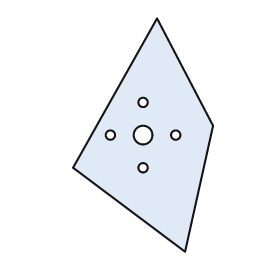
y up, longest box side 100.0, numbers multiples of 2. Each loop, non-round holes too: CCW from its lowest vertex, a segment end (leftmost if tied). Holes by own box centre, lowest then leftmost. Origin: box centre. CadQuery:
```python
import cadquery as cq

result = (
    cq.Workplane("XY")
    .moveTo(18.0, -50.0)
    .lineTo(30.0, 4.0)
    .lineTo(6.0, 50.0)
    .lineTo(-30.0, -14.0)
    .close()
    .moveTo(0.0, -14.0)
    .circle(2.0)
    .moveTo(-14.0, 0.0)
    .circle(2.0)
    .moveTo(0.0, 0.0)
    .circle(4.0)
    .moveTo(14.0, 0.0)
    .circle(2.0)
    .moveTo(0.0, 14.0)
    .circle(2.0)
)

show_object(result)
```